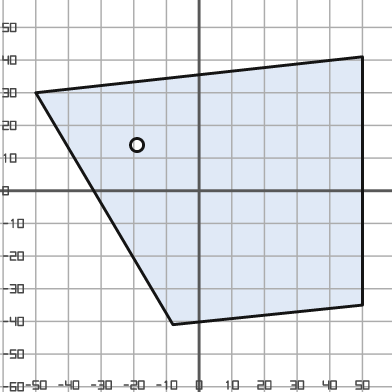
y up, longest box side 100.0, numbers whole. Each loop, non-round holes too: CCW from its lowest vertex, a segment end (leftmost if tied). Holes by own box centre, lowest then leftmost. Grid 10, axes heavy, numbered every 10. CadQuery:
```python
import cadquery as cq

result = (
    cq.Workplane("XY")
    .moveTo(-8.0, -41.0)
    .lineTo(50.0, -35.0)
    .lineTo(50.0, 41.0)
    .lineTo(-50.0, 30.0)
    .close()
    .moveTo(-19.0, 14.0)
    .circle(2.0)
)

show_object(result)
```